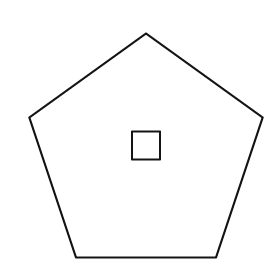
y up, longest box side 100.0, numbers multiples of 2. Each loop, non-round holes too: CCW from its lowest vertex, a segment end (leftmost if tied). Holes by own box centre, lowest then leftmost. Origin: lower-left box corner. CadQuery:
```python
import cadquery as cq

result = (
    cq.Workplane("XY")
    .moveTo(20.0, 0.0)
    .lineTo(80.0, 0.0)
    .lineTo(100.0, 60.0)
    .lineTo(50.0, 96.0)
    .lineTo(0.0, 60.0)
    .close()
    .moveTo(44.0, 42.0)
    .lineTo(56.0, 42.0)
    .lineTo(56.0, 54.0)
    .lineTo(44.0, 54.0)
    .close()
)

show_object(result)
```